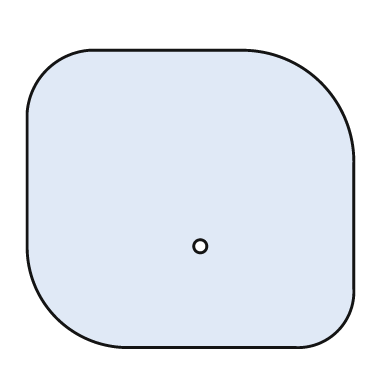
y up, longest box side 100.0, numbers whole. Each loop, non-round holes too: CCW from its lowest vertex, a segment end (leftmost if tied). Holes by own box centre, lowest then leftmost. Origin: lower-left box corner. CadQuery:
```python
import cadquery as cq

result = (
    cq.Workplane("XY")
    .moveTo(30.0, 0.0)
    .lineTo(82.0, 0.0)
    .threePointArc((95.0, 5.0), (100.0, 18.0))
    .lineTo(100.0, 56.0)
    .threePointArc((90.0, 81.0), (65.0, 91.0))
    .lineTo(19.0, 91.0)
    .threePointArc((6.0, 85.0), (0.0, 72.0))
    .lineTo(0.0, 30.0)
    .threePointArc((9.0, 9.0), (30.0, 0.0))
    .close()
    .moveTo(53.0, 31.0)
    .circle(2.0)
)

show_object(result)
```